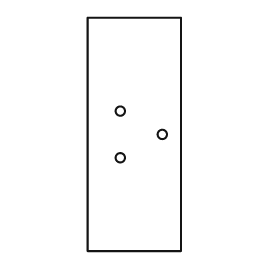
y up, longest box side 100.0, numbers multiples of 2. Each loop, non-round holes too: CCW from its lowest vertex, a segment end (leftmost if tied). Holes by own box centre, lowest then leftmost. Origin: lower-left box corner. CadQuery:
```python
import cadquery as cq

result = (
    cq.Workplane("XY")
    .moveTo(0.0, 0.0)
    .lineTo(40.0, 0.0)
    .lineTo(40.0, 100.0)
    .lineTo(0.0, 100.0)
    .close()
    .moveTo(14.0, 40.0)
    .circle(2.0)
    .moveTo(32.0, 50.0)
    .circle(2.0)
    .moveTo(14.0, 60.0)
    .circle(2.0)
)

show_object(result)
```